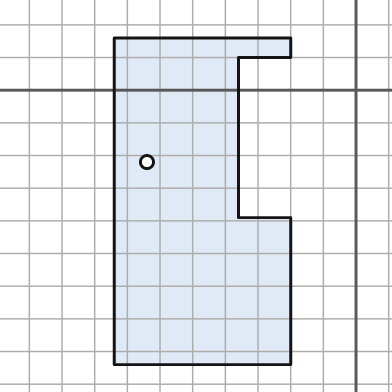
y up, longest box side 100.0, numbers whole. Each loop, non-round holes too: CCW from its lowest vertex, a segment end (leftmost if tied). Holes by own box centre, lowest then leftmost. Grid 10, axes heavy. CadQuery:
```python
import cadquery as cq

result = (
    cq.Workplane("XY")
    .moveTo(-74.0, -84.0)
    .lineTo(-20.0, -84.0)
    .lineTo(-20.0, -39.0)
    .lineTo(-36.0, -39.0)
    .lineTo(-36.0, 10.0)
    .lineTo(-20.0, 10.0)
    .lineTo(-20.0, 16.0)
    .lineTo(-74.0, 16.0)
    .close()
    .moveTo(-64.0, -22.0)
    .circle(2.0)
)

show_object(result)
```